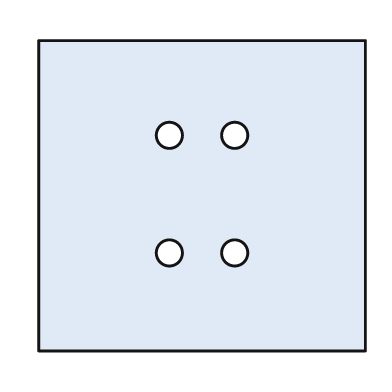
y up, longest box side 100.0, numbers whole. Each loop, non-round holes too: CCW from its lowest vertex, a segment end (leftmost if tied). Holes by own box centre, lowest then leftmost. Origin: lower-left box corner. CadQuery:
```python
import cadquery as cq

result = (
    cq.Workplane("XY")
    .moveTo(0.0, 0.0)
    .lineTo(100.0, 0.0)
    .lineTo(100.0, 95.0)
    .lineTo(0.0, 95.0)
    .close()
    .moveTo(40.0, 30.0)
    .circle(4.0)
    .moveTo(60.0, 30.0)
    .circle(4.0)
    .moveTo(40.0, 66.0)
    .circle(4.0)
    .moveTo(60.0, 66.0)
    .circle(4.0)
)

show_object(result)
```